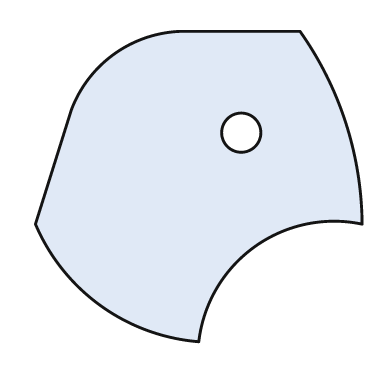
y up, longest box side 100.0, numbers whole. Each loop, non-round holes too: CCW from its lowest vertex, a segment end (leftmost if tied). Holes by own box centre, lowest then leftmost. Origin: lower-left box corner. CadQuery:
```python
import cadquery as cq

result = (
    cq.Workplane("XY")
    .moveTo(50.0, 0.0)
    .threePointArc((67.0, 29.0), (100.0, 36.0))
    .threePointArc((95.0, 67.0), (81.0, 95.0))
    .lineTo(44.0, 95.0)
    .threePointArc((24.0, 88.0), (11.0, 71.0))
    .lineTo(0.0, 36.0)
    .threePointArc((20.0, 11.0), (50.0, 0.0))
    .close()
    .moveTo(63.0, 64.0)
    .circle(6.0)
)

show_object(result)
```